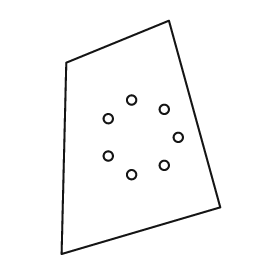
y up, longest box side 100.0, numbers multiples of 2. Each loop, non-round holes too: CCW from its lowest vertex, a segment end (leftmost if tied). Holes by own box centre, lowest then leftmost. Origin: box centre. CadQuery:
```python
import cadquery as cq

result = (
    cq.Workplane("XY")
    .moveTo(-34.0, -50.0)
    .lineTo(34.0, -30.0)
    .lineTo(12.0, 50.0)
    .lineTo(-32.0, 32.0)
    .close()
    .moveTo(-4.0, -16.0)
    .circle(2.0)
    .moveTo(10.0, -12.0)
    .circle(2.0)
    .moveTo(-14.0, -8.0)
    .circle(2.0)
    .moveTo(16.0, 0.0)
    .circle(2.0)
    .moveTo(-14.0, 8.0)
    .circle(2.0)
    .moveTo(10.0, 12.0)
    .circle(2.0)
    .moveTo(-4.0, 16.0)
    .circle(2.0)
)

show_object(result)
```